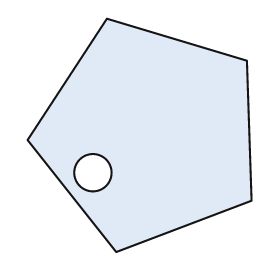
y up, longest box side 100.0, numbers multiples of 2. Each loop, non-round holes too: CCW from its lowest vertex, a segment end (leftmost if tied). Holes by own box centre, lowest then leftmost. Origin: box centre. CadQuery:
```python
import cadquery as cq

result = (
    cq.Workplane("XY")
    .moveTo(-10.0, -50.0)
    .lineTo(48.0, -28.0)
    .lineTo(46.0, 32.0)
    .lineTo(-14.0, 50.0)
    .lineTo(-48.0, -2.0)
    .close()
    .moveTo(-20.0, -16.0)
    .circle(8.0)
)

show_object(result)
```